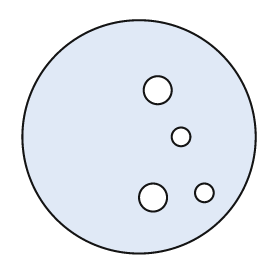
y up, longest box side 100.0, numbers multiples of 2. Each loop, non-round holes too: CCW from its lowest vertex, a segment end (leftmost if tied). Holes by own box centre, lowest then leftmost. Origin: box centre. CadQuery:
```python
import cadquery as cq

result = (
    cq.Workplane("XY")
    .moveTo(0.0, 0.0)
    .circle(50.0)
    .moveTo(6.0, -26.0)
    .circle(6.0)
    .moveTo(28.0, -24.0)
    .circle(4.0)
    .moveTo(18.0, 0.0)
    .circle(4.0)
    .moveTo(8.0, 20.0)
    .circle(6.0)
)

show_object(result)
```